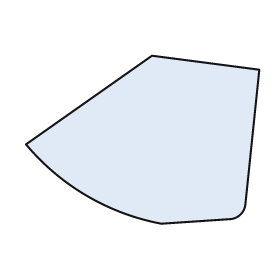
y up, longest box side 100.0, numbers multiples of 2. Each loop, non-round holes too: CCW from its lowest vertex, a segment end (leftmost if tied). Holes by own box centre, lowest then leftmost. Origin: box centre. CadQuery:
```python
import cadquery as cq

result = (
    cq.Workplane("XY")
    .moveTo(8.0, -36.0)
    .lineTo(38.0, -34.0)
    .threePointArc((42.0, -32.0), (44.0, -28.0))
    .lineTo(50.0, 30.0)
    .lineTo(4.0, 36.0)
    .lineTo(-50.0, -2.0)
    .threePointArc((-24.0, -24.0), (8.0, -36.0))
    .close()
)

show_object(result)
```